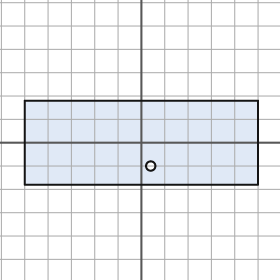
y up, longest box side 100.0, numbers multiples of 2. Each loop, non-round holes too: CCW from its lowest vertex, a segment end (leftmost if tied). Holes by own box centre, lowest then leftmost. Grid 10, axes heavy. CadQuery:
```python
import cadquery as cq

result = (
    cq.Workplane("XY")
    .moveTo(-50.0, -18.0)
    .lineTo(50.0, -18.0)
    .lineTo(50.0, 18.0)
    .lineTo(-50.0, 18.0)
    .close()
    .moveTo(4.0, -10.0)
    .circle(2.0)
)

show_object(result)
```